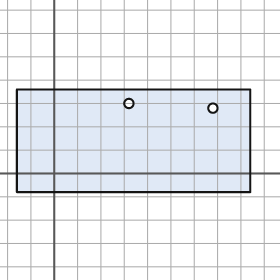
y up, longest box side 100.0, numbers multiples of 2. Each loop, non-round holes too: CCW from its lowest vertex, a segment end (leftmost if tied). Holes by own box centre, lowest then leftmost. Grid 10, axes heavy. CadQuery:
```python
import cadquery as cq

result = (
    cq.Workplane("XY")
    .moveTo(-16.0, -8.0)
    .lineTo(84.0, -8.0)
    .lineTo(84.0, 36.0)
    .lineTo(-16.0, 36.0)
    .close()
    .moveTo(68.0, 28.0)
    .circle(2.0)
    .moveTo(32.0, 30.0)
    .circle(2.0)
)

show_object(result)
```